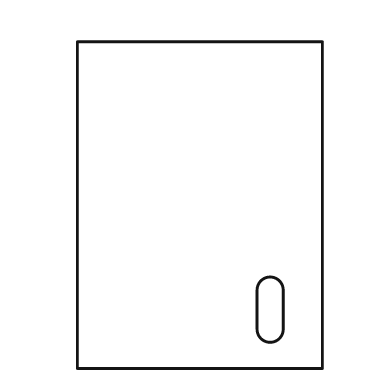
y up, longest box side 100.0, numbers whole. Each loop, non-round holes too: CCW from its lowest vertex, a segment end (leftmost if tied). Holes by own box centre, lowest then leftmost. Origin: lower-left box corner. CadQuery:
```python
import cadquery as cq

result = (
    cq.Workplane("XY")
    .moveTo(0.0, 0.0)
    .lineTo(75.0, 0.0)
    .lineTo(75.0, 100.0)
    .lineTo(0.0, 100.0)
    .close()
    .moveTo(55.0, 12.0)
    .threePointArc((59.0, 8.0), (63.0, 12.0))
    .lineTo(63.0, 24.0)
    .threePointArc((59.0, 28.0), (55.0, 24.0))
    .close()
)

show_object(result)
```